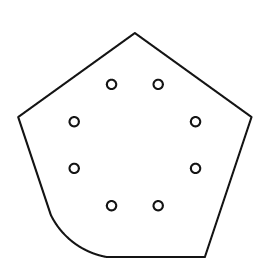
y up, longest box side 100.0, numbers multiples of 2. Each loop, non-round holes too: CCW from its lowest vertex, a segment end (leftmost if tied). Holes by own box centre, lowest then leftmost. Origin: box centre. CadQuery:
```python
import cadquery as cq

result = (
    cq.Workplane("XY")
    .moveTo(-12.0, -48.0)
    .lineTo(30.0, -48.0)
    .lineTo(50.0, 12.0)
    .lineTo(0.0, 48.0)
    .lineTo(-50.0, 12.0)
    .lineTo(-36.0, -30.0)
    .threePointArc((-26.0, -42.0), (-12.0, -48.0))
    .close()
    .moveTo(-10.0, -26.0)
    .circle(2.0)
    .moveTo(10.0, -26.0)
    .circle(2.0)
    .moveTo(-26.0, -10.0)
    .circle(2.0)
    .moveTo(26.0, -10.0)
    .circle(2.0)
    .moveTo(-26.0, 10.0)
    .circle(2.0)
    .moveTo(26.0, 10.0)
    .circle(2.0)
    .moveTo(-10.0, 26.0)
    .circle(2.0)
    .moveTo(10.0, 26.0)
    .circle(2.0)
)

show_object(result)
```